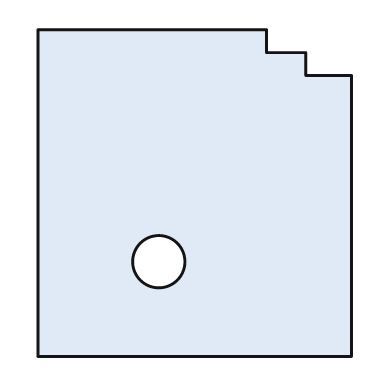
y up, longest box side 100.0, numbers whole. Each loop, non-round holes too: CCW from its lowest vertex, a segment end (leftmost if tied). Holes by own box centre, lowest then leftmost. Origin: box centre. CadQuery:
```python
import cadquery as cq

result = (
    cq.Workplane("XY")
    .moveTo(-48.0, -50.0)
    .lineTo(48.0, -50.0)
    .lineTo(48.0, 36.0)
    .lineTo(34.0, 36.0)
    .lineTo(34.0, 43.0)
    .lineTo(22.0, 43.0)
    .lineTo(22.0, 50.0)
    .lineTo(-48.0, 50.0)
    .close()
    .moveTo(-11.0, -21.0)
    .circle(8.0)
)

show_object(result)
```